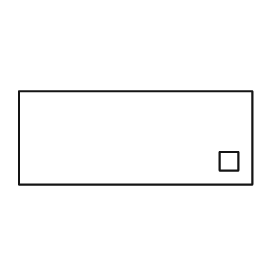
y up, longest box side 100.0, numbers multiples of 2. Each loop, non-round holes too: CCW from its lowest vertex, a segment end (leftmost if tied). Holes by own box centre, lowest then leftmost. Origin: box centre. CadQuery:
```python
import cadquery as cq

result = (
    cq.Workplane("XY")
    .moveTo(-50.0, -20.0)
    .lineTo(50.0, -20.0)
    .lineTo(50.0, 20.0)
    .lineTo(-50.0, 20.0)
    .close()
    .moveTo(36.0, -14.0)
    .lineTo(44.0, -14.0)
    .lineTo(44.0, -6.0)
    .lineTo(36.0, -6.0)
    .close()
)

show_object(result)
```